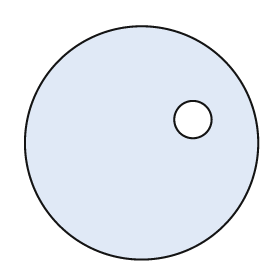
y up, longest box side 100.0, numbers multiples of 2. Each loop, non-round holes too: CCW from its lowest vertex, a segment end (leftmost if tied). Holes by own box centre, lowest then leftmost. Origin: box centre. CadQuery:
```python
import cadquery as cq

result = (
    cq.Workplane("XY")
    .moveTo(0.0, 0.0)
    .circle(50.0)
    .moveTo(22.0, 10.0)
    .circle(8.0)
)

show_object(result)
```